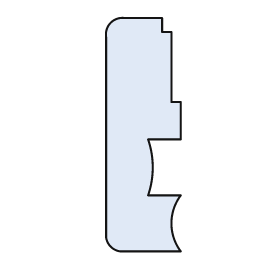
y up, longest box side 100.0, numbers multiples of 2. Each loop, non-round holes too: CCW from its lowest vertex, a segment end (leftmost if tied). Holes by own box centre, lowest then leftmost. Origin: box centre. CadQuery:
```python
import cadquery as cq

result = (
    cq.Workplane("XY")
    .moveTo(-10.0, -50.0)
    .lineTo(16.0, -50.0)
    .threePointArc((12.0, -38.0), (16.0, -26.0))
    .lineTo(2.0, -26.0)
    .threePointArc((4.0, -14.0), (2.0, -2.0))
    .lineTo(16.0, -2.0)
    .lineTo(16.0, 14.0)
    .lineTo(12.0, 14.0)
    .lineTo(12.0, 44.0)
    .lineTo(8.0, 44.0)
    .lineTo(8.0, 50.0)
    .lineTo(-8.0, 50.0)
    .threePointArc((-14.0, 48.0), (-16.0, 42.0))
    .lineTo(-16.0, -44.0)
    .threePointArc((-14.0, -48.0), (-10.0, -50.0))
    .close()
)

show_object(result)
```